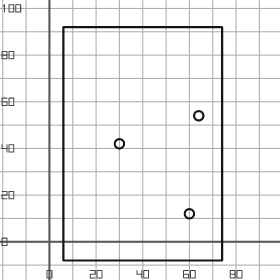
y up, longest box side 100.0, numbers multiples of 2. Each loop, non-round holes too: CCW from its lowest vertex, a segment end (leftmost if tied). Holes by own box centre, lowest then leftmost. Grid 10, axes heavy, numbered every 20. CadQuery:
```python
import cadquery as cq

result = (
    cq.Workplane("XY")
    .moveTo(6.0, -8.0)
    .lineTo(74.0, -8.0)
    .lineTo(74.0, 92.0)
    .lineTo(6.0, 92.0)
    .close()
    .moveTo(60.0, 12.0)
    .circle(2.0)
    .moveTo(30.0, 42.0)
    .circle(2.0)
    .moveTo(64.0, 54.0)
    .circle(2.0)
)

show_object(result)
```